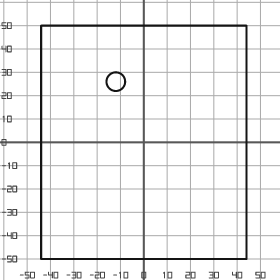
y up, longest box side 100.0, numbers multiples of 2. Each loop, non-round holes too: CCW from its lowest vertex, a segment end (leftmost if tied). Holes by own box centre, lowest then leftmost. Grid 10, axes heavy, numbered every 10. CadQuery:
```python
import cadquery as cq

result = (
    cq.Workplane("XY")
    .moveTo(-44.0, -50.0)
    .lineTo(44.0, -50.0)
    .lineTo(44.0, 50.0)
    .lineTo(-44.0, 50.0)
    .close()
    .moveTo(-12.0, 26.0)
    .circle(4.0)
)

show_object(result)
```